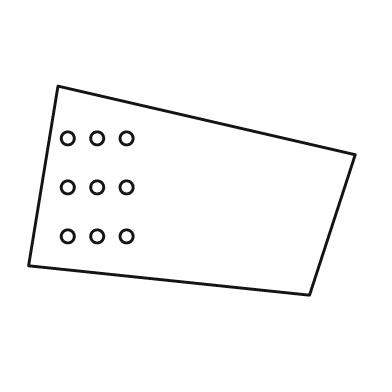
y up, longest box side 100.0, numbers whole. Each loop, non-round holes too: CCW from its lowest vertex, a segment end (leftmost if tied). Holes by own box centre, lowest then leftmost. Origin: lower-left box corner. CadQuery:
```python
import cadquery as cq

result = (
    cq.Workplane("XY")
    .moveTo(86.0, 0.0)
    .lineTo(100.0, 43.0)
    .lineTo(9.0, 64.0)
    .lineTo(0.0, 9.0)
    .close()
    .moveTo(12.0, 18.0)
    .circle(2.0)
    .moveTo(21.0, 18.0)
    .circle(2.0)
    .moveTo(30.0, 18.0)
    .circle(2.0)
    .moveTo(12.0, 33.0)
    .circle(2.0)
    .moveTo(21.0, 33.0)
    .circle(2.0)
    .moveTo(30.0, 33.0)
    .circle(2.0)
    .moveTo(12.0, 48.0)
    .circle(2.0)
    .moveTo(21.0, 48.0)
    .circle(2.0)
    .moveTo(30.0, 48.0)
    .circle(2.0)
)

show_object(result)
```